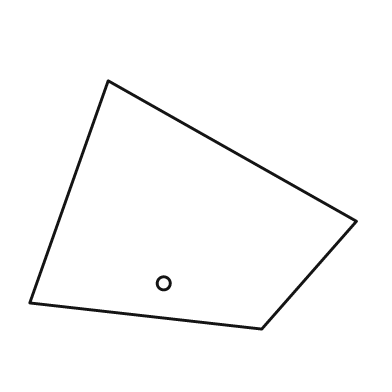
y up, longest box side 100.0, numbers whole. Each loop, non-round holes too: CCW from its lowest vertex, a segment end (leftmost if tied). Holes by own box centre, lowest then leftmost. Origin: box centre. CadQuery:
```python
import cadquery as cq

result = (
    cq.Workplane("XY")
    .moveTo(21.0, -38.0)
    .lineTo(50.0, -5.0)
    .lineTo(-26.0, 38.0)
    .lineTo(-50.0, -30.0)
    .close()
    .moveTo(-9.0, -24.0)
    .circle(2.0)
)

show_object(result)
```